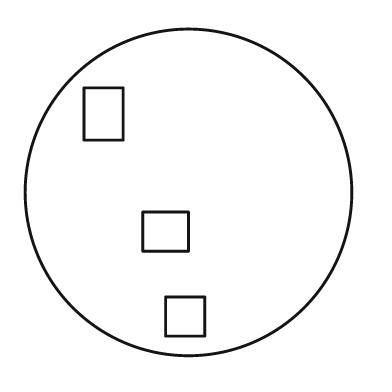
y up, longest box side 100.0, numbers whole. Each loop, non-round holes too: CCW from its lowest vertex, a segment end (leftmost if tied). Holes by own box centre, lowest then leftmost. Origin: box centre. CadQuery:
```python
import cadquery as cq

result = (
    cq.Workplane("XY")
    .moveTo(0.0, 0.0)
    .circle(50.0)
    .moveTo(-7.0, -44.0)
    .lineTo(5.0, -44.0)
    .lineTo(5.0, -32.0)
    .lineTo(-7.0, -32.0)
    .close()
    .moveTo(-14.0, -18.0)
    .lineTo(0.0, -18.0)
    .lineTo(0.0, -6.0)
    .lineTo(-14.0, -6.0)
    .close()
    .moveTo(-32.0, 16.0)
    .lineTo(-20.0, 16.0)
    .lineTo(-20.0, 32.0)
    .lineTo(-32.0, 32.0)
    .close()
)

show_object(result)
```